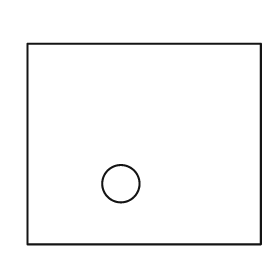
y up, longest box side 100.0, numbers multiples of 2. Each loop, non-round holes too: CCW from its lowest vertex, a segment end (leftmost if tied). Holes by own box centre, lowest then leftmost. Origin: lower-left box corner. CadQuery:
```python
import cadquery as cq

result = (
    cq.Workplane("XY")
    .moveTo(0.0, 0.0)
    .lineTo(100.0, 0.0)
    .lineTo(100.0, 86.0)
    .lineTo(0.0, 86.0)
    .close()
    .moveTo(40.0, 26.0)
    .circle(8.0)
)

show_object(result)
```